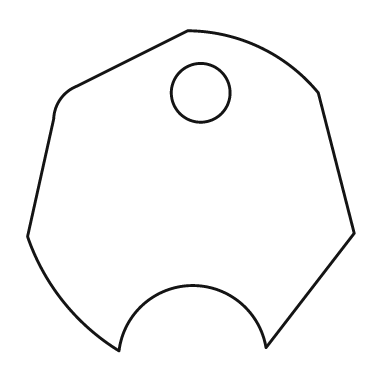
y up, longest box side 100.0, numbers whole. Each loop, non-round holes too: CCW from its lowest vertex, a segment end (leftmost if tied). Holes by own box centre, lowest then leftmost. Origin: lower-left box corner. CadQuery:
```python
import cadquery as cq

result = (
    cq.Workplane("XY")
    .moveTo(28.0, 0.0)
    .threePointArc((50.0, 20.0), (73.0, 1.0))
    .lineTo(100.0, 36.0)
    .lineTo(89.0, 79.0)
    .threePointArc((71.0, 93.0), (49.0, 98.0))
    .lineTo(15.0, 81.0)
    .threePointArc((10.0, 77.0), (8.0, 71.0))
    .lineTo(0.0, 35.0)
    .threePointArc((11.0, 15.0), (28.0, 0.0))
    .close()
    .moveTo(53.0, 79.0)
    .circle(9.0)
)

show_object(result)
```